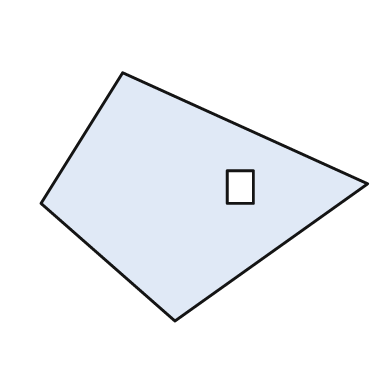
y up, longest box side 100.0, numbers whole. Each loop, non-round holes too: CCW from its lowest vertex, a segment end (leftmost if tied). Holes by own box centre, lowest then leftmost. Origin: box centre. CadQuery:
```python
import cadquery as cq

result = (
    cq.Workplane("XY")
    .moveTo(-9.0, -38.0)
    .lineTo(50.0, 4.0)
    .lineTo(-25.0, 38.0)
    .lineTo(-50.0, -2.0)
    .close()
    .moveTo(7.0, -2.0)
    .lineTo(15.0, -2.0)
    .lineTo(15.0, 8.0)
    .lineTo(7.0, 8.0)
    .close()
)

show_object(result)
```